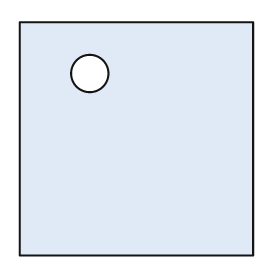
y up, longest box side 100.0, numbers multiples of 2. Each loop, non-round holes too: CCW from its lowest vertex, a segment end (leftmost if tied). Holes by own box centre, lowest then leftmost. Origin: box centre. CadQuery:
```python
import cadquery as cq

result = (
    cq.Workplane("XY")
    .moveTo(-50.0, -50.0)
    .lineTo(50.0, -50.0)
    .lineTo(50.0, 50.0)
    .lineTo(-50.0, 50.0)
    .close()
    .moveTo(-20.0, 28.0)
    .circle(8.0)
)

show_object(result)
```